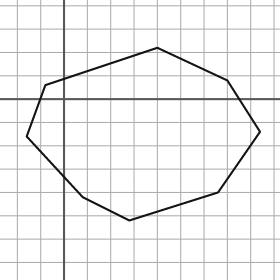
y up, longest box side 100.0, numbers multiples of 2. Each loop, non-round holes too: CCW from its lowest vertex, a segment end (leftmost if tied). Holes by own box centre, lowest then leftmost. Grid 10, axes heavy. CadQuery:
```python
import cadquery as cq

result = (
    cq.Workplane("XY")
    .moveTo(28.0, -52.0)
    .lineTo(66.0, -40.0)
    .lineTo(84.0, -14.0)
    .lineTo(70.0, 8.0)
    .lineTo(40.0, 22.0)
    .lineTo(-8.0, 6.0)
    .lineTo(-16.0, -16.0)
    .lineTo(8.0, -42.0)
    .close()
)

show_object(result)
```